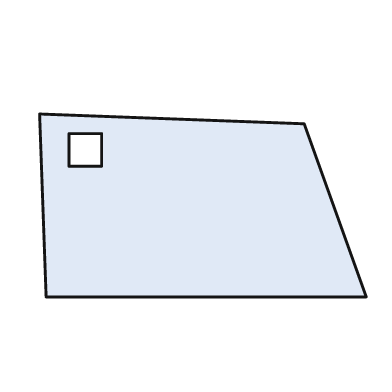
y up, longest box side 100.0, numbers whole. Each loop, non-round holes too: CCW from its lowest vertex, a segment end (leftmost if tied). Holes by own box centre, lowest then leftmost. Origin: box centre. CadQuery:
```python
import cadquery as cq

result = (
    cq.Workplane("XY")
    .moveTo(-48.0, -28.0)
    .lineTo(50.0, -28.0)
    .lineTo(31.0, 25.0)
    .lineTo(-50.0, 28.0)
    .close()
    .moveTo(-41.0, 12.0)
    .lineTo(-31.0, 12.0)
    .lineTo(-31.0, 22.0)
    .lineTo(-41.0, 22.0)
    .close()
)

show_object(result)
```